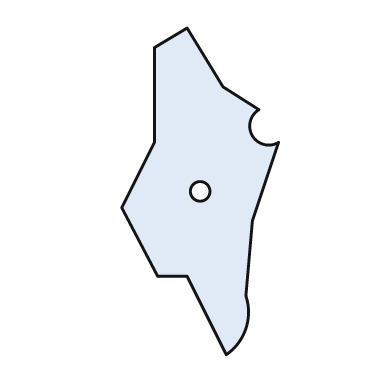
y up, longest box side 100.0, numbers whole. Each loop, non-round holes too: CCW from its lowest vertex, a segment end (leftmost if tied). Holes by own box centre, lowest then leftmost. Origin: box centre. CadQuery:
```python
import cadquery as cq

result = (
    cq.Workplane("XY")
    .moveTo(8.0, -50.0)
    .threePointArc((14.0, -42.0), (14.0, -32.0))
    .lineTo(16.0, -9.0)
    .lineTo(24.0, 15.0)
    .threePointArc((16.0, 17.0), (18.0, 25.0))
    .lineTo(7.0, 32.0)
    .lineTo(-4.0, 50.0)
    .lineTo(-14.0, 44.0)
    .lineTo(-14.0, 15.0)
    .lineTo(-24.0, -5.0)
    .lineTo(-13.0, -26.0)
    .lineTo(-4.0, -26.0)
    .close()
    .moveTo(0.0, 0.0)
    .circle(3.0)
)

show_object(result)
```